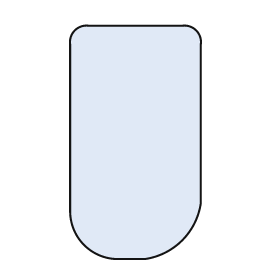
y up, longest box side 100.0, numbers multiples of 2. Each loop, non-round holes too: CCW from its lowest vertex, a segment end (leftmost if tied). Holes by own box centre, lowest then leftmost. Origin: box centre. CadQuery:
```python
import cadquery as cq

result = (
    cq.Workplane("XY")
    .moveTo(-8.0, -50.0)
    .lineTo(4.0, -50.0)
    .threePointArc((20.0, -42.0), (28.0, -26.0))
    .lineTo(28.0, 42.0)
    .threePointArc((26.0, 48.0), (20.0, 50.0))
    .lineTo(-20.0, 50.0)
    .threePointArc((-26.0, 48.0), (-28.0, 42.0))
    .lineTo(-28.0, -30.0)
    .threePointArc((-22.0, -44.0), (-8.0, -50.0))
    .close()
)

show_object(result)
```